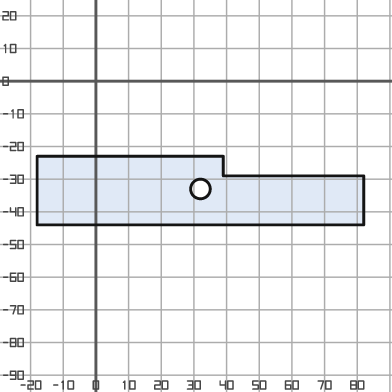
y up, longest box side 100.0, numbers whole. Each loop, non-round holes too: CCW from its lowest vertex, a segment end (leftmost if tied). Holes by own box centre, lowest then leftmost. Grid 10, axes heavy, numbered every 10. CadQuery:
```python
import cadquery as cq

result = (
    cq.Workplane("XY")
    .moveTo(-18.0, -44.0)
    .lineTo(82.0, -44.0)
    .lineTo(82.0, -29.0)
    .lineTo(39.0, -29.0)
    .lineTo(39.0, -23.0)
    .lineTo(-18.0, -23.0)
    .close()
    .moveTo(32.0, -33.0)
    .circle(3.0)
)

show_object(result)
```